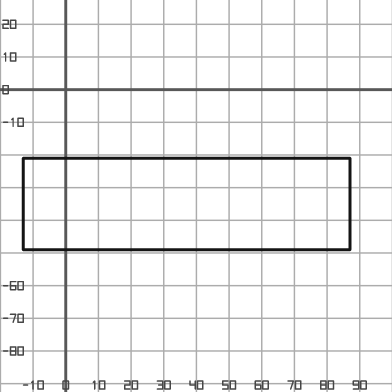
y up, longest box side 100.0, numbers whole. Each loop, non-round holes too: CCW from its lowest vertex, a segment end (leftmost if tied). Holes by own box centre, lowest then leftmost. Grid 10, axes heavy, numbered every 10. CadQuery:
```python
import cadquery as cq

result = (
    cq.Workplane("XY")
    .moveTo(-13.0, -49.0)
    .lineTo(87.0, -49.0)
    .lineTo(87.0, -21.0)
    .lineTo(-13.0, -21.0)
    .close()
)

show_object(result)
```